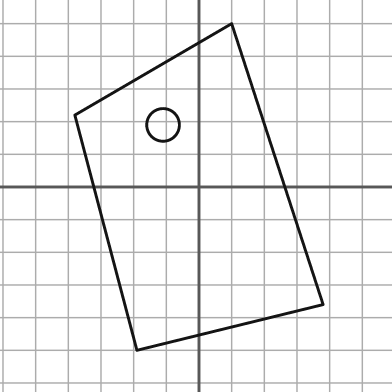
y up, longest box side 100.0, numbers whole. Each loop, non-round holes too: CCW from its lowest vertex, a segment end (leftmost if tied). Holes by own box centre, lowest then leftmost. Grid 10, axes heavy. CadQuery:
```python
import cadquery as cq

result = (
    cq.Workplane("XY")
    .moveTo(-19.0, -50.0)
    .lineTo(38.0, -36.0)
    .lineTo(10.0, 50.0)
    .lineTo(-38.0, 22.0)
    .close()
    .moveTo(-11.0, 19.0)
    .circle(5.0)
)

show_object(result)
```